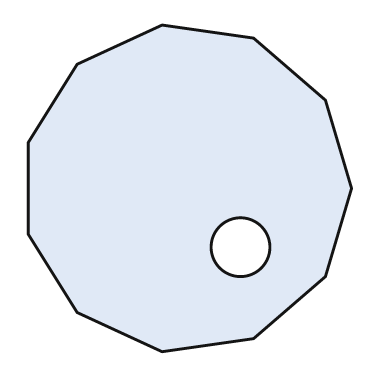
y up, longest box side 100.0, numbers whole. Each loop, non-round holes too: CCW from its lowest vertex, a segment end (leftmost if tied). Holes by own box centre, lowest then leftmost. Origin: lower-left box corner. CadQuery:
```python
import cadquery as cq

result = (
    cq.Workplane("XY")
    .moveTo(41.0, 0.0)
    .lineTo(69.0, 4.0)
    .lineTo(91.0, 23.0)
    .lineTo(99.0, 50.0)
    .lineTo(91.0, 77.0)
    .lineTo(69.0, 96.0)
    .lineTo(41.0, 100.0)
    .lineTo(15.0, 88.0)
    .lineTo(0.0, 64.0)
    .lineTo(0.0, 36.0)
    .lineTo(15.0, 12.0)
    .close()
    .moveTo(65.0, 32.0)
    .circle(9.0)
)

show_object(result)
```